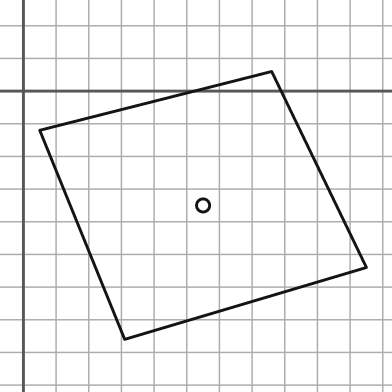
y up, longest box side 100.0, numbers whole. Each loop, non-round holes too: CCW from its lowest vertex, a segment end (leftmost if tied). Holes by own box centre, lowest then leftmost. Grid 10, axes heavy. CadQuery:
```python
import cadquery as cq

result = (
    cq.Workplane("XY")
    .moveTo(31.0, -76.0)
    .lineTo(105.0, -54.0)
    .lineTo(76.0, 6.0)
    .lineTo(5.0, -12.0)
    .close()
    .moveTo(55.0, -35.0)
    .circle(2.0)
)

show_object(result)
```